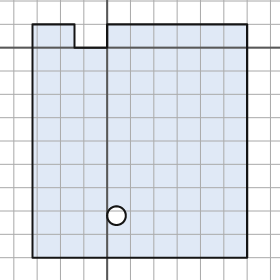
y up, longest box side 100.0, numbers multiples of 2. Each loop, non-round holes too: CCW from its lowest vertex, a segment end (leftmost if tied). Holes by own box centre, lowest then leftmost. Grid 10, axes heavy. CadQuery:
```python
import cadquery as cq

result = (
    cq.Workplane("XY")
    .moveTo(-32.0, -90.0)
    .lineTo(60.0, -90.0)
    .lineTo(60.0, 10.0)
    .lineTo(0.0, 10.0)
    .lineTo(0.0, 0.0)
    .lineTo(-14.0, 0.0)
    .lineTo(-14.0, 10.0)
    .lineTo(-32.0, 10.0)
    .close()
    .moveTo(4.0, -72.0)
    .circle(4.0)
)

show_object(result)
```